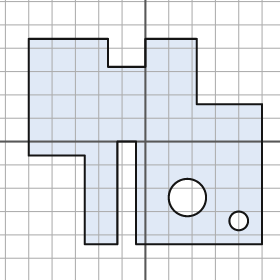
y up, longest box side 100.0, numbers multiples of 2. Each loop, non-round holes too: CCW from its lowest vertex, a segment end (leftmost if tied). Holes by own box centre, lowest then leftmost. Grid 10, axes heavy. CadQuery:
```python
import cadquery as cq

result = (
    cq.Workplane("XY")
    .moveTo(-26.0, -44.0)
    .lineTo(-12.0, -44.0)
    .lineTo(-12.0, 0.0)
    .lineTo(-4.0, 0.0)
    .lineTo(-4.0, -44.0)
    .lineTo(50.0, -44.0)
    .lineTo(50.0, 16.0)
    .lineTo(22.0, 16.0)
    .lineTo(22.0, 44.0)
    .lineTo(0.0, 44.0)
    .lineTo(0.0, 32.0)
    .lineTo(-16.0, 32.0)
    .lineTo(-16.0, 44.0)
    .lineTo(-50.0, 44.0)
    .lineTo(-50.0, -6.0)
    .lineTo(-26.0, -6.0)
    .close()
    .moveTo(40.0, -34.0)
    .circle(4.0)
    .moveTo(18.0, -24.0)
    .circle(8.0)
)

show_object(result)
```